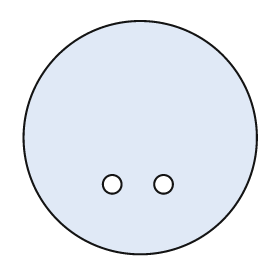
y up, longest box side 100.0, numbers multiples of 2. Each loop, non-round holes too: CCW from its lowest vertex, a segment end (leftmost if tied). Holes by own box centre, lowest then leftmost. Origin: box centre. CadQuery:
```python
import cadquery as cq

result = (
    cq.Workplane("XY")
    .moveTo(0.0, 0.0)
    .circle(50.0)
    .moveTo(-12.0, -20.0)
    .circle(4.0)
    .moveTo(10.0, -20.0)
    .circle(4.0)
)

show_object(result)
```